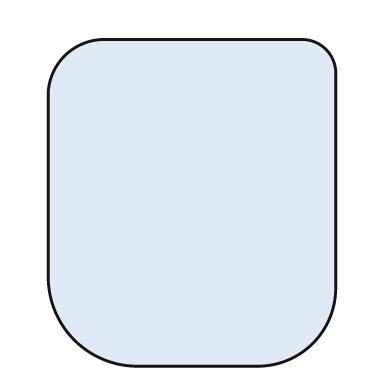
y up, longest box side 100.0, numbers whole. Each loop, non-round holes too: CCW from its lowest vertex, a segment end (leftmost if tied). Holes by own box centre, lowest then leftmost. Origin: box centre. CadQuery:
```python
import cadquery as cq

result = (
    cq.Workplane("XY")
    .moveTo(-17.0, -50.0)
    .lineTo(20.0, -50.0)
    .threePointArc((37.0, -43.0), (44.0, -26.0))
    .lineTo(44.0, 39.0)
    .threePointArc((41.0, 47.0), (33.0, 50.0))
    .lineTo(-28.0, 50.0)
    .threePointArc((-39.0, 45.0), (-44.0, 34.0))
    .lineTo(-44.0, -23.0)
    .threePointArc((-36.0, -42.0), (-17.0, -50.0))
    .close()
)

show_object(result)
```